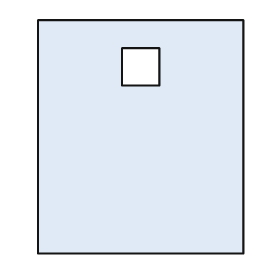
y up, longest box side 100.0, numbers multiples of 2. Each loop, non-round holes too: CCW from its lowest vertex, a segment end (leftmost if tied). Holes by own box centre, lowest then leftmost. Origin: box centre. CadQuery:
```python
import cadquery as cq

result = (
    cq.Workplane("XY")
    .moveTo(-44.0, -50.0)
    .lineTo(44.0, -50.0)
    .lineTo(44.0, 50.0)
    .lineTo(-44.0, 50.0)
    .close()
    .moveTo(-8.0, 22.0)
    .lineTo(8.0, 22.0)
    .lineTo(8.0, 38.0)
    .lineTo(-8.0, 38.0)
    .close()
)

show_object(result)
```